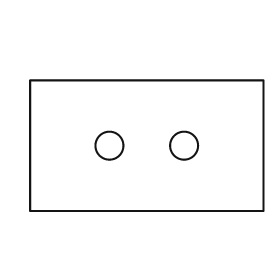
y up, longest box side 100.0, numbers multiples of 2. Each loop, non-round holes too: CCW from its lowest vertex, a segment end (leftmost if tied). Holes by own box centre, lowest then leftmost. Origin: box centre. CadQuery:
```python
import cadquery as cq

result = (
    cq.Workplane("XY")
    .moveTo(-50.0, -28.0)
    .lineTo(50.0, -28.0)
    .lineTo(50.0, 28.0)
    .lineTo(-50.0, 28.0)
    .close()
    .moveTo(-16.0, 0.0)
    .circle(6.0)
    .moveTo(16.0, 0.0)
    .circle(6.0)
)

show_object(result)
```